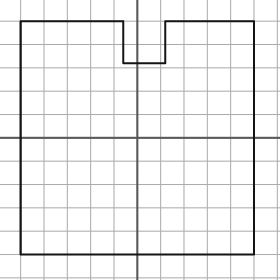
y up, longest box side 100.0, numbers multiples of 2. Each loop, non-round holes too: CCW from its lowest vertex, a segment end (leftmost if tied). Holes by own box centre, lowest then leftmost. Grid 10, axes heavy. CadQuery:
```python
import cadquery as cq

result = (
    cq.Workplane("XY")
    .moveTo(-50.0, -50.0)
    .lineTo(50.0, -50.0)
    .lineTo(50.0, 50.0)
    .lineTo(12.0, 50.0)
    .lineTo(12.0, 32.0)
    .lineTo(-6.0, 32.0)
    .lineTo(-6.0, 50.0)
    .lineTo(-50.0, 50.0)
    .close()
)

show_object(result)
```